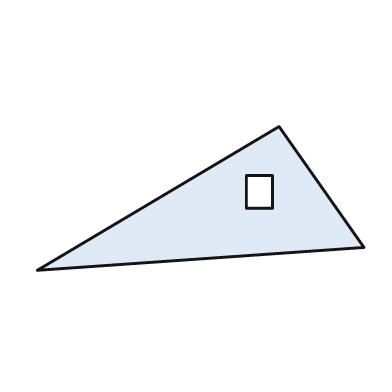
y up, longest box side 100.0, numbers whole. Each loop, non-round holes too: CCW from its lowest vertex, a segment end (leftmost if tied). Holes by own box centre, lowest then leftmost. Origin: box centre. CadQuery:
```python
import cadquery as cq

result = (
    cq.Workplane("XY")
    .moveTo(-50.0, -22.0)
    .lineTo(50.0, -15.0)
    .lineTo(24.0, 22.0)
    .close()
    .moveTo(14.0, -3.0)
    .lineTo(22.0, -3.0)
    .lineTo(22.0, 7.0)
    .lineTo(14.0, 7.0)
    .close()
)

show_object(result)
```